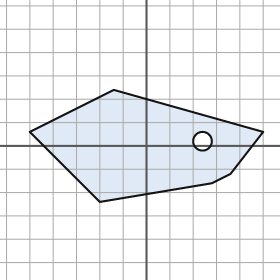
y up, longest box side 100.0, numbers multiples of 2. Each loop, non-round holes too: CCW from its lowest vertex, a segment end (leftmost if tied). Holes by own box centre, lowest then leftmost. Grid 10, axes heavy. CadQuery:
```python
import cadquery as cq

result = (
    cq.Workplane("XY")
    .moveTo(-20.0, -24.0)
    .lineTo(28.0, -16.0)
    .lineTo(36.0, -12.0)
    .lineTo(50.0, 6.0)
    .lineTo(-14.0, 24.0)
    .lineTo(-50.0, 6.0)
    .close()
    .moveTo(24.0, 2.0)
    .circle(4.0)
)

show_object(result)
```